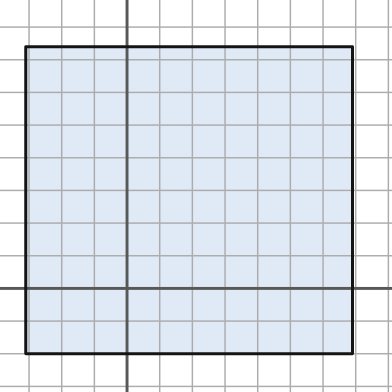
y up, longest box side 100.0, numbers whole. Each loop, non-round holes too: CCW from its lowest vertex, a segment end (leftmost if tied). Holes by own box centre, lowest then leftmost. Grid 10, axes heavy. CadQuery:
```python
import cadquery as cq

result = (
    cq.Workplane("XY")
    .moveTo(-31.0, -20.0)
    .lineTo(69.0, -20.0)
    .lineTo(69.0, 74.0)
    .lineTo(-31.0, 74.0)
    .close()
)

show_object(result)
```